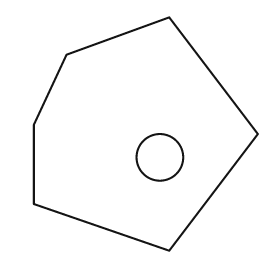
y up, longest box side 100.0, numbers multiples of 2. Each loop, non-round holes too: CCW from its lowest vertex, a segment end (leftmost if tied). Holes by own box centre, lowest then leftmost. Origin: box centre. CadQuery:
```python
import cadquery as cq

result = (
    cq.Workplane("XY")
    .moveTo(10.0, -50.0)
    .lineTo(48.0, 0.0)
    .lineTo(10.0, 50.0)
    .lineTo(-34.0, 34.0)
    .lineTo(-48.0, 4.0)
    .lineTo(-48.0, -30.0)
    .close()
    .moveTo(6.0, -10.0)
    .circle(10.0)
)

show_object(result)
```